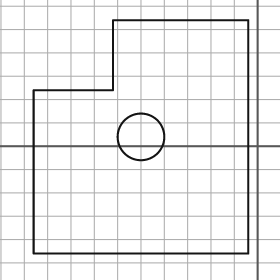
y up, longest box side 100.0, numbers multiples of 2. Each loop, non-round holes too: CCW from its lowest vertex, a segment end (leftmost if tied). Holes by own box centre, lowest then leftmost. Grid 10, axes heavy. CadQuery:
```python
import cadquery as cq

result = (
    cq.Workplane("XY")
    .moveTo(-96.0, -46.0)
    .lineTo(-4.0, -46.0)
    .lineTo(-4.0, 54.0)
    .lineTo(-62.0, 54.0)
    .lineTo(-62.0, 24.0)
    .lineTo(-96.0, 24.0)
    .close()
    .moveTo(-50.0, 4.0)
    .circle(10.0)
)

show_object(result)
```